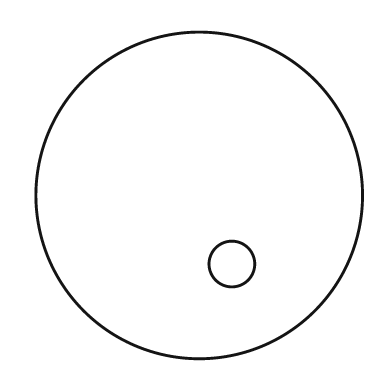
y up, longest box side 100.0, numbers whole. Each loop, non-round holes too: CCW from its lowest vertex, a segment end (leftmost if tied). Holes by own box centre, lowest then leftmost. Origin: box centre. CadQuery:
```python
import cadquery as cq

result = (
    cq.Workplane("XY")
    .moveTo(0.0, 0.0)
    .circle(50.0)
    .moveTo(10.0, -21.0)
    .circle(7.0)
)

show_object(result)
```